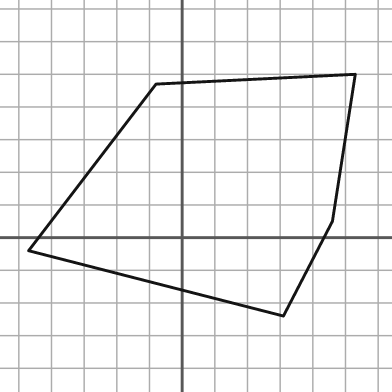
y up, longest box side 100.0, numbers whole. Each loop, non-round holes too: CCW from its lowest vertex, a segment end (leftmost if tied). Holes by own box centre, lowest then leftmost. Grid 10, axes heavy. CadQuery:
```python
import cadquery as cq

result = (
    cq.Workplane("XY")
    .moveTo(31.0, -24.0)
    .lineTo(46.0, 5.0)
    .lineTo(53.0, 50.0)
    .lineTo(-8.0, 47.0)
    .lineTo(-47.0, -4.0)
    .close()
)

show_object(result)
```